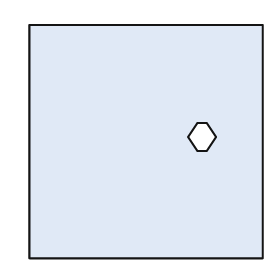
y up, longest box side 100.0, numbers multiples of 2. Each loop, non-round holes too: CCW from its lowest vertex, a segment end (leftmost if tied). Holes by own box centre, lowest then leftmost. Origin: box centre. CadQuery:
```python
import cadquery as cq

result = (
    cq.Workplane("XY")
    .moveTo(-50.0, -50.0)
    .lineTo(50.0, -50.0)
    .lineTo(50.0, 50.0)
    .lineTo(-50.0, 50.0)
    .close()
    .moveTo(22.0, -4.0)
    .lineTo(26.0, -4.0)
    .lineTo(30.0, 2.0)
    .lineTo(26.0, 8.0)
    .lineTo(22.0, 8.0)
    .lineTo(18.0, 2.0)
    .close()
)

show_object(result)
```